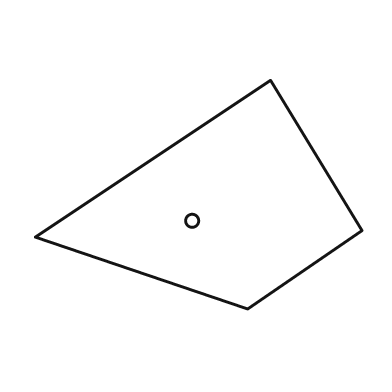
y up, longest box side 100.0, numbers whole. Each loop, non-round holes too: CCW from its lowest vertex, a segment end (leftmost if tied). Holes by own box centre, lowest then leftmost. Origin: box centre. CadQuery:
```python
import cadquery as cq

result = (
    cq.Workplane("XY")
    .moveTo(15.0, -35.0)
    .lineTo(50.0, -11.0)
    .lineTo(22.0, 35.0)
    .lineTo(-50.0, -13.0)
    .close()
    .moveTo(-2.0, -8.0)
    .circle(2.0)
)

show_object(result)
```